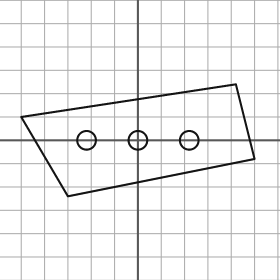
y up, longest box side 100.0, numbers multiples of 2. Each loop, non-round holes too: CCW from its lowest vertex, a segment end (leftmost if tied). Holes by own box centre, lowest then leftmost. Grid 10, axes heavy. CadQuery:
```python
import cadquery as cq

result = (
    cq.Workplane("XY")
    .moveTo(-30.0, -24.0)
    .lineTo(50.0, -8.0)
    .lineTo(42.0, 24.0)
    .lineTo(-50.0, 10.0)
    .close()
    .moveTo(-22.0, 0.0)
    .circle(4.0)
    .moveTo(0.0, 0.0)
    .circle(4.0)
    .moveTo(22.0, 0.0)
    .circle(4.0)
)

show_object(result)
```